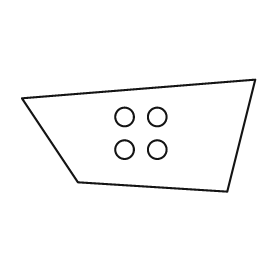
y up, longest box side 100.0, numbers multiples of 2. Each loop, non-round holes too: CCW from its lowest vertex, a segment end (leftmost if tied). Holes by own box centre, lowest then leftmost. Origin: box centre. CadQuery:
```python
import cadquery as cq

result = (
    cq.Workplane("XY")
    .moveTo(38.0, -24.0)
    .lineTo(50.0, 24.0)
    .lineTo(-50.0, 16.0)
    .lineTo(-26.0, -20.0)
    .close()
    .moveTo(-6.0, -6.0)
    .circle(4.0)
    .moveTo(8.0, -6.0)
    .circle(4.0)
    .moveTo(-6.0, 8.0)
    .circle(4.0)
    .moveTo(8.0, 8.0)
    .circle(4.0)
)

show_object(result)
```